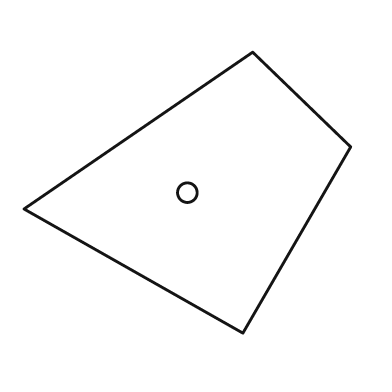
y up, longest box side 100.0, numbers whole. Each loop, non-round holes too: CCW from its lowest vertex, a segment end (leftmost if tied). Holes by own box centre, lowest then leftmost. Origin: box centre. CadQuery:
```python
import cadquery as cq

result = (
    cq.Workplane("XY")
    .moveTo(17.0, -43.0)
    .lineTo(50.0, 14.0)
    .lineTo(20.0, 43.0)
    .lineTo(-50.0, -5.0)
    .close()
    .moveTo(0.0, 0.0)
    .circle(3.0)
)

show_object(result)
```